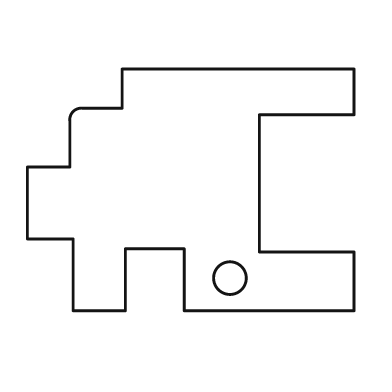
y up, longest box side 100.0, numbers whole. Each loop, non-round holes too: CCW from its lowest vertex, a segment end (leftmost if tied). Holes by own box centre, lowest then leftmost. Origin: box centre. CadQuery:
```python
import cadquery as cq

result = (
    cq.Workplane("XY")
    .moveTo(-36.0, -37.0)
    .lineTo(-20.0, -37.0)
    .lineTo(-20.0, -18.0)
    .lineTo(-2.0, -18.0)
    .lineTo(-2.0, -37.0)
    .lineTo(50.0, -37.0)
    .lineTo(50.0, -19.0)
    .lineTo(21.0, -19.0)
    .lineTo(21.0, 23.0)
    .lineTo(50.0, 23.0)
    .lineTo(50.0, 37.0)
    .lineTo(-21.0, 37.0)
    .lineTo(-21.0, 25.0)
    .lineTo(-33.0, 25.0)
    .threePointArc((-36.0, 24.0), (-37.0, 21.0))
    .lineTo(-37.0, 7.0)
    .lineTo(-50.0, 7.0)
    .lineTo(-50.0, -15.0)
    .lineTo(-36.0, -15.0)
    .close()
    .moveTo(12.0, -27.0)
    .circle(5.0)
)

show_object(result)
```